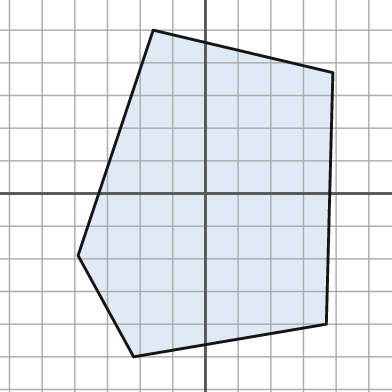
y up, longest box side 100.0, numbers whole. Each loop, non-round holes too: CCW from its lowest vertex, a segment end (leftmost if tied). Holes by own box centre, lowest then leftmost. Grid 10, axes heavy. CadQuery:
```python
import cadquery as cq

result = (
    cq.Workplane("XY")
    .moveTo(-22.0, -50.0)
    .lineTo(37.0, -40.0)
    .lineTo(39.0, 37.0)
    .lineTo(-16.0, 50.0)
    .lineTo(-39.0, -19.0)
    .close()
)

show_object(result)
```